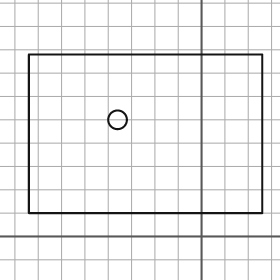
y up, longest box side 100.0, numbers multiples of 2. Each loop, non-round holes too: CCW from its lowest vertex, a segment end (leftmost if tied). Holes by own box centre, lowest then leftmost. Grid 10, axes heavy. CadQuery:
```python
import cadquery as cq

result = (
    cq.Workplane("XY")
    .moveTo(-74.0, 10.0)
    .lineTo(26.0, 10.0)
    .lineTo(26.0, 78.0)
    .lineTo(-74.0, 78.0)
    .close()
    .moveTo(-36.0, 50.0)
    .circle(4.0)
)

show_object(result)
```